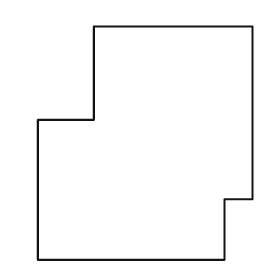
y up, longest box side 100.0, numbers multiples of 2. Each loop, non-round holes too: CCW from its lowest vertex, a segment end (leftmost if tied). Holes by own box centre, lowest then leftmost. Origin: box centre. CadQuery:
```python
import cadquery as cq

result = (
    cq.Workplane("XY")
    .moveTo(-46.0, -50.0)
    .lineTo(34.0, -50.0)
    .lineTo(34.0, -24.0)
    .lineTo(46.0, -24.0)
    .lineTo(46.0, 50.0)
    .lineTo(-22.0, 50.0)
    .lineTo(-22.0, 10.0)
    .lineTo(-46.0, 10.0)
    .close()
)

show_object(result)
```